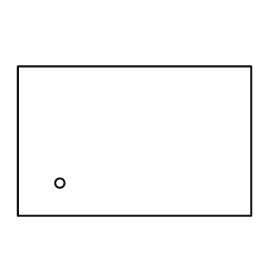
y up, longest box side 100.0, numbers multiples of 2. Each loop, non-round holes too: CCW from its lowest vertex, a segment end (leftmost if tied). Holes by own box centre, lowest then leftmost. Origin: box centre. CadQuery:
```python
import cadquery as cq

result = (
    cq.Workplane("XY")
    .moveTo(-50.0, -32.0)
    .lineTo(50.0, -32.0)
    .lineTo(50.0, 32.0)
    .lineTo(-50.0, 32.0)
    .close()
    .moveTo(-32.0, -18.0)
    .circle(2.0)
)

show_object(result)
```